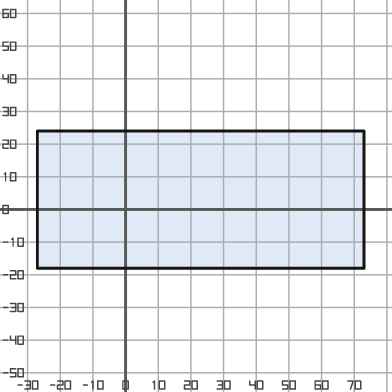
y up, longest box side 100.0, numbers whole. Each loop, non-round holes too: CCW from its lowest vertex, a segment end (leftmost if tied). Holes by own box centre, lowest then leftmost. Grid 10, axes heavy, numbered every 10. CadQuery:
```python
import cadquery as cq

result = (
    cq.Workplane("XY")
    .moveTo(-27.0, -18.0)
    .lineTo(73.0, -18.0)
    .lineTo(73.0, 24.0)
    .lineTo(-27.0, 24.0)
    .close()
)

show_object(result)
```